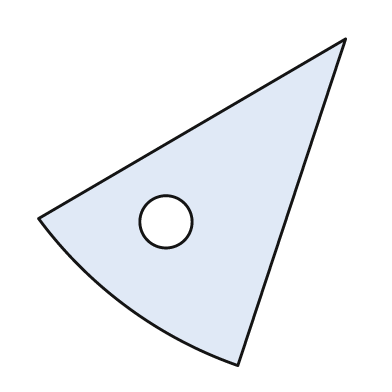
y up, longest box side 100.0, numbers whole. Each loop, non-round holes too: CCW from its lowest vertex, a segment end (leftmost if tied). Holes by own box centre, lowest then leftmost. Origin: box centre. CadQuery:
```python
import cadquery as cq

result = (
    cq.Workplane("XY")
    .moveTo(14.0, -50.0)
    .lineTo(47.0, 50.0)
    .lineTo(-47.0, -5.0)
    .threePointArc((-20.0, -32.0), (14.0, -50.0))
    .close()
    .moveTo(-8.0, -6.0)
    .circle(8.0)
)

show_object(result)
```